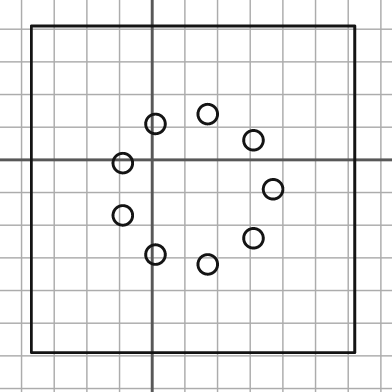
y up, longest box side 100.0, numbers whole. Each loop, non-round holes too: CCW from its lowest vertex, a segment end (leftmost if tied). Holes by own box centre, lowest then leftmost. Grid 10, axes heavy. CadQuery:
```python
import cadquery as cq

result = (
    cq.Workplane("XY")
    .moveTo(-37.0, -59.0)
    .lineTo(62.0, -59.0)
    .lineTo(62.0, 41.0)
    .lineTo(-37.0, 41.0)
    .close()
    .moveTo(17.0, -32.0)
    .circle(3.0)
    .moveTo(1.0, -29.0)
    .circle(3.0)
    .moveTo(31.0, -24.0)
    .circle(3.0)
    .moveTo(-9.0, -17.0)
    .circle(3.0)
    .moveTo(37.0, -9.0)
    .circle(3.0)
    .moveTo(-9.0, -1.0)
    .circle(3.0)
    .moveTo(31.0, 6.0)
    .circle(3.0)
    .moveTo(1.0, 11.0)
    .circle(3.0)
    .moveTo(17.0, 14.0)
    .circle(3.0)
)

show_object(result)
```